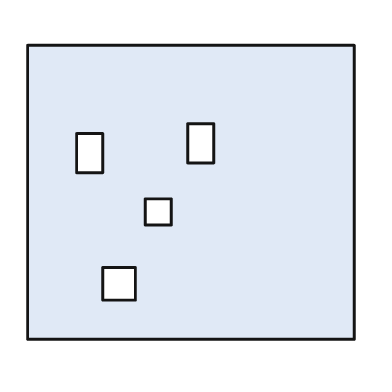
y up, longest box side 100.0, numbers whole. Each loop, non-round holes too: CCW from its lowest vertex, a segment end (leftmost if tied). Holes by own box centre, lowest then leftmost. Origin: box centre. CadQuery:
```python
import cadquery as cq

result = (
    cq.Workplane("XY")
    .moveTo(-50.0, -45.0)
    .lineTo(50.0, -45.0)
    .lineTo(50.0, 45.0)
    .lineTo(-50.0, 45.0)
    .close()
    .moveTo(-27.0, -33.0)
    .lineTo(-17.0, -33.0)
    .lineTo(-17.0, -23.0)
    .lineTo(-27.0, -23.0)
    .close()
    .moveTo(-14.0, -10.0)
    .lineTo(-6.0, -10.0)
    .lineTo(-6.0, -2.0)
    .lineTo(-14.0, -2.0)
    .close()
    .moveTo(-35.0, 6.0)
    .lineTo(-27.0, 6.0)
    .lineTo(-27.0, 18.0)
    .lineTo(-35.0, 18.0)
    .close()
    .moveTo(-1.0, 9.0)
    .lineTo(7.0, 9.0)
    .lineTo(7.0, 21.0)
    .lineTo(-1.0, 21.0)
    .close()
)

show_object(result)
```